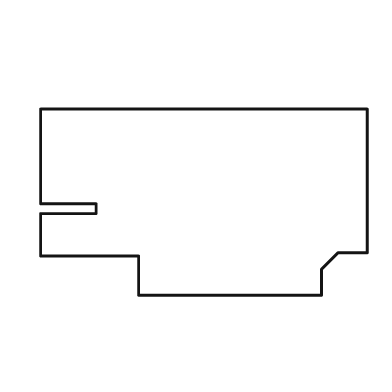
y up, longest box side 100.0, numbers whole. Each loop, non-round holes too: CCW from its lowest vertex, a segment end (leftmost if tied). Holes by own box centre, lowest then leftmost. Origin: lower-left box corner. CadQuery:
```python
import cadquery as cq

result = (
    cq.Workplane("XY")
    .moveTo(30.0, 0.0)
    .lineTo(86.0, 0.0)
    .lineTo(86.0, 8.0)
    .lineTo(91.0, 13.0)
    .lineTo(100.0, 13.0)
    .lineTo(100.0, 57.0)
    .lineTo(0.0, 57.0)
    .lineTo(0.0, 28.0)
    .lineTo(17.0, 28.0)
    .lineTo(17.0, 25.0)
    .lineTo(0.0, 25.0)
    .lineTo(0.0, 12.0)
    .lineTo(30.0, 12.0)
    .close()
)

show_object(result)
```